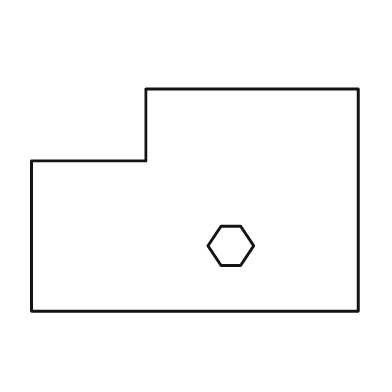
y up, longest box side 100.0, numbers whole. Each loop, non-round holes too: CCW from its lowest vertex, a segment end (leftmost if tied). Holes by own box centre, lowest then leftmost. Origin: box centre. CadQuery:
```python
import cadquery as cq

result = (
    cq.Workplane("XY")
    .moveTo(-50.0, -34.0)
    .lineTo(50.0, -34.0)
    .lineTo(50.0, 34.0)
    .lineTo(-15.0, 34.0)
    .lineTo(-15.0, 12.0)
    .lineTo(-50.0, 12.0)
    .close()
    .moveTo(8.0, -20.0)
    .lineTo(14.0, -20.0)
    .lineTo(18.0, -14.0)
    .lineTo(14.0, -8.0)
    .lineTo(8.0, -8.0)
    .lineTo(4.0, -14.0)
    .close()
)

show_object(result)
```